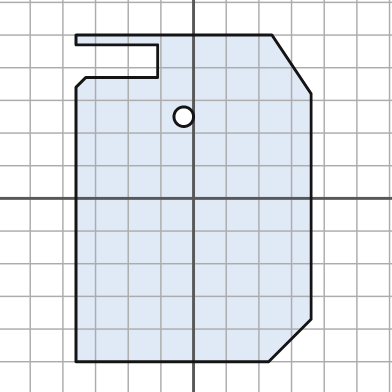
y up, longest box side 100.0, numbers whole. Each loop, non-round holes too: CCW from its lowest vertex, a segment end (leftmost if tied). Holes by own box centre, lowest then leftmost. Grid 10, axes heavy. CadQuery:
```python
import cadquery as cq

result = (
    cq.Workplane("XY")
    .moveTo(-36.0, -50.0)
    .lineTo(23.0, -50.0)
    .lineTo(36.0, -37.0)
    .lineTo(36.0, 32.0)
    .lineTo(24.0, 50.0)
    .lineTo(-36.0, 50.0)
    .lineTo(-36.0, 47.0)
    .lineTo(-11.0, 47.0)
    .lineTo(-11.0, 37.0)
    .lineTo(-33.0, 37.0)
    .lineTo(-36.0, 34.0)
    .close()
    .moveTo(-3.0, 25.0)
    .circle(3.0)
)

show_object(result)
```